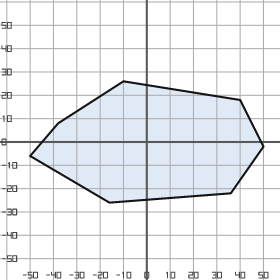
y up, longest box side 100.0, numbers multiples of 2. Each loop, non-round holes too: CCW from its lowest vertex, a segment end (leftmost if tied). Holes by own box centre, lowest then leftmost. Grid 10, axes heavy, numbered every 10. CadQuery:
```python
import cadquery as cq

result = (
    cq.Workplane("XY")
    .moveTo(-16.0, -26.0)
    .lineTo(36.0, -22.0)
    .lineTo(50.0, -2.0)
    .lineTo(40.0, 18.0)
    .lineTo(-10.0, 26.0)
    .lineTo(-38.0, 8.0)
    .lineTo(-50.0, -6.0)
    .close()
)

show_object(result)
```